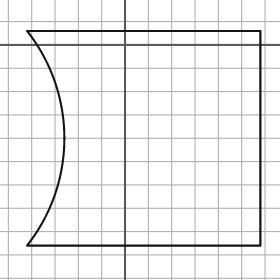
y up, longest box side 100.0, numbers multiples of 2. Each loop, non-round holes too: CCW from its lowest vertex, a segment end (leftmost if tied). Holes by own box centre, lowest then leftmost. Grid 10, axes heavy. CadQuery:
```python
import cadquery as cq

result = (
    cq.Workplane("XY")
    .moveTo(-42.0, -86.0)
    .lineTo(58.0, -86.0)
    .lineTo(58.0, 6.0)
    .lineTo(-42.0, 6.0)
    .threePointArc((-26.0, -40.0), (-42.0, -86.0))
    .close()
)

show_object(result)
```